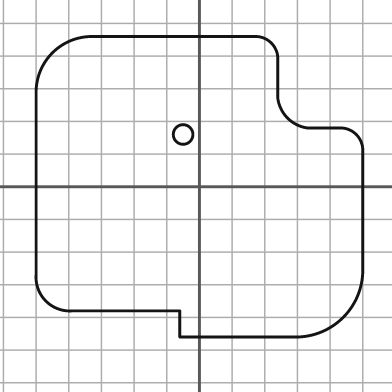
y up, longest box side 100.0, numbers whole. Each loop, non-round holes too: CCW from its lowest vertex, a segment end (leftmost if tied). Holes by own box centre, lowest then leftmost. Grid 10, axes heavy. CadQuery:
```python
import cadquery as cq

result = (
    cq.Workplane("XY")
    .moveTo(-6.0, -46.0)
    .lineTo(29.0, -46.0)
    .threePointArc((44.0, -40.0), (50.0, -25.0))
    .lineTo(50.0, 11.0)
    .threePointArc((48.0, 16.0), (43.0, 18.0))
    .lineTo(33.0, 18.0)
    .threePointArc((27.0, 21.0), (24.0, 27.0))
    .lineTo(24.0, 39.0)
    .threePointArc((22.0, 44.0), (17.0, 46.0))
    .lineTo(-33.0, 46.0)
    .threePointArc((-45.0, 41.0), (-50.0, 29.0))
    .lineTo(-50.0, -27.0)
    .threePointArc((-47.0, -35.0), (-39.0, -38.0))
    .lineTo(-6.0, -38.0)
    .close()
    .moveTo(-5.0, 16.0)
    .circle(3.0)
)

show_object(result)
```